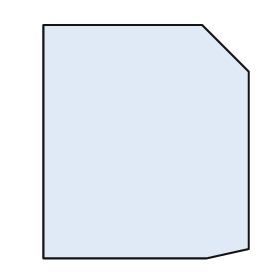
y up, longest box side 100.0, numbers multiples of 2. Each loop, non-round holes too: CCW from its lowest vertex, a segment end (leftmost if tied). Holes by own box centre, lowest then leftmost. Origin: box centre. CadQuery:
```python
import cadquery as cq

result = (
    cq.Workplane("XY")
    .moveTo(-44.0, -50.0)
    .lineTo(26.0, -50.0)
    .lineTo(44.0, -46.0)
    .lineTo(44.0, 30.0)
    .lineTo(24.0, 50.0)
    .lineTo(-44.0, 50.0)
    .close()
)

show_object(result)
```